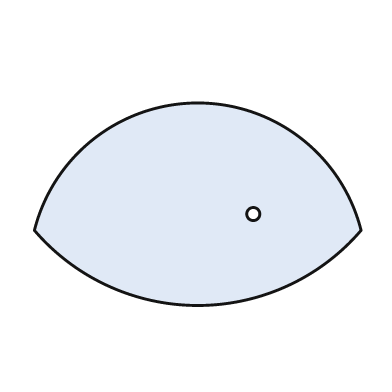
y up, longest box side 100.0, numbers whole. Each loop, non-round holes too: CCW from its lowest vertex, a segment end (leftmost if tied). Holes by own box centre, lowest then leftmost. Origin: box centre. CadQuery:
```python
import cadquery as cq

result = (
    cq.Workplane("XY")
    .moveTo(-50.0, -8.0)
    .threePointArc((0.0, -31.0), (50.0, -8.0))
    .threePointArc((0.0, 31.0), (-50.0, -8.0))
    .close()
    .moveTo(17.0, -3.0)
    .circle(2.0)
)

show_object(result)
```